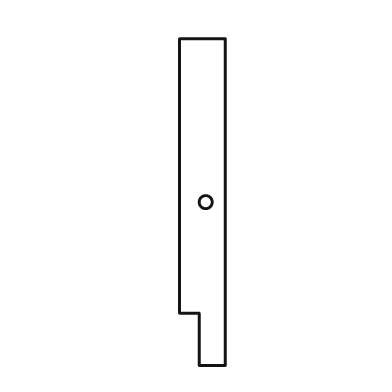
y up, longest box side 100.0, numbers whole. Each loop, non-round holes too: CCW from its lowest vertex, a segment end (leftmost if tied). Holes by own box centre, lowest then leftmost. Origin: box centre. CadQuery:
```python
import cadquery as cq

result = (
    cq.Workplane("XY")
    .moveTo(-1.0, -50.0)
    .lineTo(7.0, -50.0)
    .lineTo(7.0, 50.0)
    .lineTo(-7.0, 50.0)
    .lineTo(-7.0, -34.0)
    .lineTo(-1.0, -34.0)
    .close()
    .moveTo(1.0, 0.0)
    .circle(2.0)
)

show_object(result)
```